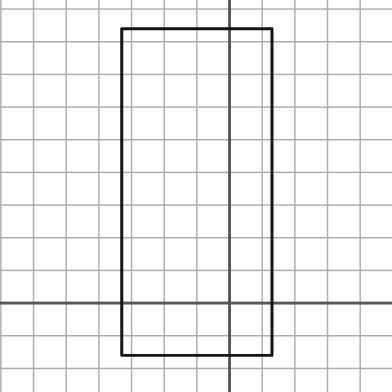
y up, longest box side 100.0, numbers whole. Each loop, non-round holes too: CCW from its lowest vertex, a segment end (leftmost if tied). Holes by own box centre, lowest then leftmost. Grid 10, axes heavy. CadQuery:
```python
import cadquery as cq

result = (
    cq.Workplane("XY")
    .moveTo(-33.0, -16.0)
    .lineTo(13.0, -16.0)
    .lineTo(13.0, 84.0)
    .lineTo(-33.0, 84.0)
    .close()
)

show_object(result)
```